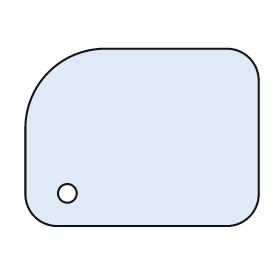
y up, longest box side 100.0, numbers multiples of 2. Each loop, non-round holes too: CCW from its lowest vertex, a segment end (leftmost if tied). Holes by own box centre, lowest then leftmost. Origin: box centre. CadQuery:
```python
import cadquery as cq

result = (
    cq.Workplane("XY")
    .moveTo(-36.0, -38.0)
    .lineTo(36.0, -38.0)
    .threePointArc((46.0, -34.0), (50.0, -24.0))
    .lineTo(50.0, 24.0)
    .threePointArc((46.0, 34.0), (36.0, 38.0))
    .lineTo(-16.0, 38.0)
    .threePointArc((-40.0, 28.0), (-50.0, 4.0))
    .lineTo(-50.0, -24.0)
    .threePointArc((-46.0, -34.0), (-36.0, -38.0))
    .close()
    .moveTo(-32.0, -24.0)
    .circle(4.0)
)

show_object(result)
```